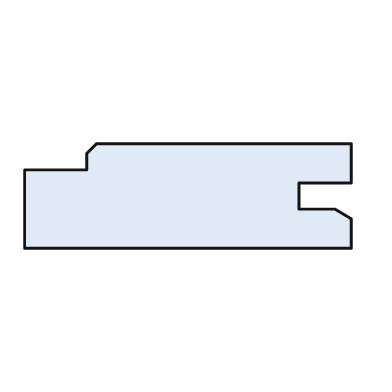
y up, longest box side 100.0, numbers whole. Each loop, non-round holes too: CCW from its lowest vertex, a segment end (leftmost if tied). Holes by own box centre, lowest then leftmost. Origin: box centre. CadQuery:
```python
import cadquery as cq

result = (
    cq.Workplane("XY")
    .moveTo(-50.0, -16.0)
    .lineTo(50.0, -16.0)
    .lineTo(50.0, -7.0)
    .lineTo(45.0, -4.0)
    .lineTo(34.0, -4.0)
    .lineTo(34.0, 4.0)
    .lineTo(50.0, 4.0)
    .lineTo(50.0, 16.0)
    .lineTo(-28.0, 16.0)
    .lineTo(-31.0, 13.0)
    .lineTo(-31.0, 8.0)
    .lineTo(-50.0, 8.0)
    .close()
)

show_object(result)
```